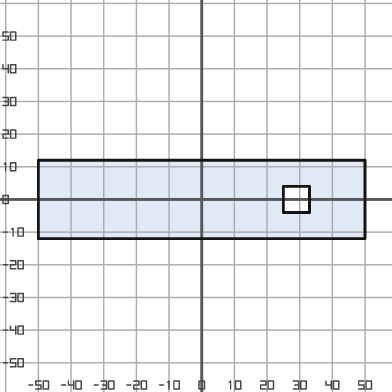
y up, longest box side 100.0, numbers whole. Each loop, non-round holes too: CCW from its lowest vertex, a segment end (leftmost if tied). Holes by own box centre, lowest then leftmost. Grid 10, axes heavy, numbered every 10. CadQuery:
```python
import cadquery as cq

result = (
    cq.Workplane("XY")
    .moveTo(-50.0, -12.0)
    .lineTo(50.0, -12.0)
    .lineTo(50.0, 12.0)
    .lineTo(-50.0, 12.0)
    .close()
    .moveTo(25.0, -4.0)
    .lineTo(33.0, -4.0)
    .lineTo(33.0, 4.0)
    .lineTo(25.0, 4.0)
    .close()
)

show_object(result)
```